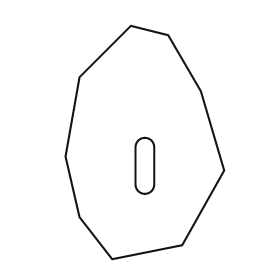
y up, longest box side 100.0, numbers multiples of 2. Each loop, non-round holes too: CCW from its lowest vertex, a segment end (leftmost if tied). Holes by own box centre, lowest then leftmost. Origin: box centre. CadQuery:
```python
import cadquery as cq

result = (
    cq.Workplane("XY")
    .moveTo(-14.0, -50.0)
    .lineTo(16.0, -44.0)
    .lineTo(34.0, -12.0)
    .lineTo(24.0, 22.0)
    .lineTo(10.0, 46.0)
    .lineTo(-6.0, 50.0)
    .lineTo(-28.0, 28.0)
    .lineTo(-34.0, -6.0)
    .lineTo(-28.0, -32.0)
    .close()
    .moveTo(-4.0, -18.0)
    .threePointArc((0.0, -22.0), (4.0, -18.0))
    .lineTo(4.0, -2.0)
    .threePointArc((0.0, 2.0), (-4.0, -2.0))
    .close()
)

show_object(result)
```